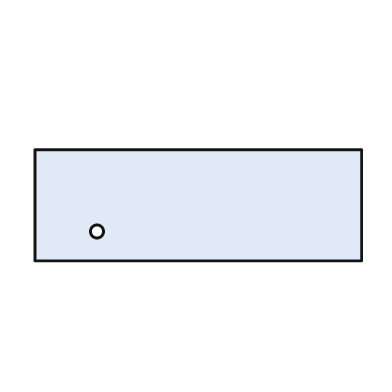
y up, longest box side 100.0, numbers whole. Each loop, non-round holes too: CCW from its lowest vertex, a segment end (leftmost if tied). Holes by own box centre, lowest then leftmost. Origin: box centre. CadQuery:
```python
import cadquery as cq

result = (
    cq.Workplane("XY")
    .moveTo(-50.0, -17.0)
    .lineTo(50.0, -17.0)
    .lineTo(50.0, 17.0)
    .lineTo(-50.0, 17.0)
    .close()
    .moveTo(-31.0, -8.0)
    .circle(2.0)
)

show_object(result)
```